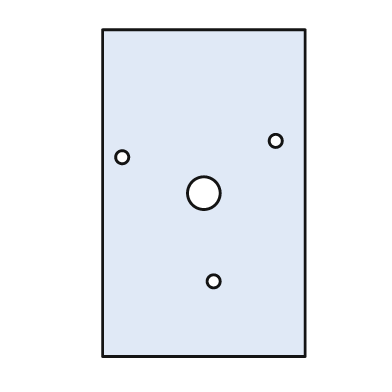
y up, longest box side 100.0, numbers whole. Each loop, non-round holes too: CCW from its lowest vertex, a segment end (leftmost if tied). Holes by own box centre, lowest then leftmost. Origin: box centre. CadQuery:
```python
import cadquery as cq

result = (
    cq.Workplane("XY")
    .moveTo(-31.0, -50.0)
    .lineTo(31.0, -50.0)
    .lineTo(31.0, 50.0)
    .lineTo(-31.0, 50.0)
    .close()
    .moveTo(3.0, -27.0)
    .circle(2.0)
    .moveTo(0.0, 0.0)
    .circle(5.0)
    .moveTo(-25.0, 11.0)
    .circle(2.0)
    .moveTo(22.0, 16.0)
    .circle(2.0)
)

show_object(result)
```